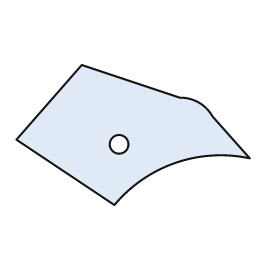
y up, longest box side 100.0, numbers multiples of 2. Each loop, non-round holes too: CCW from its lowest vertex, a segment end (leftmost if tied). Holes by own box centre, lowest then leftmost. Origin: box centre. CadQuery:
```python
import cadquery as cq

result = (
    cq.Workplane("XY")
    .moveTo(-8.0, -30.0)
    .threePointArc((18.0, -12.0), (50.0, -10.0))
    .lineTo(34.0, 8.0)
    .threePointArc((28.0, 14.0), (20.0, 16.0))
    .lineTo(-22.0, 30.0)
    .lineTo(-50.0, -2.0)
    .close()
    .moveTo(-6.0, -4.0)
    .circle(4.0)
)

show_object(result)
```